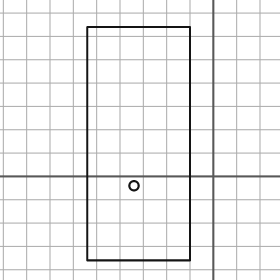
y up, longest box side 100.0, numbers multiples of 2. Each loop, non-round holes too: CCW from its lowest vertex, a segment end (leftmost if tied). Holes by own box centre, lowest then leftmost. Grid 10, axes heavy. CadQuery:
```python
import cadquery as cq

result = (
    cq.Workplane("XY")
    .moveTo(-54.0, -36.0)
    .lineTo(-10.0, -36.0)
    .lineTo(-10.0, 64.0)
    .lineTo(-54.0, 64.0)
    .close()
    .moveTo(-34.0, -4.0)
    .circle(2.0)
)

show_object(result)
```